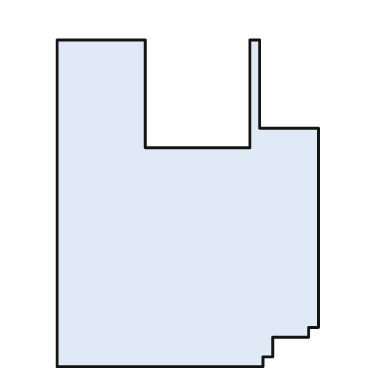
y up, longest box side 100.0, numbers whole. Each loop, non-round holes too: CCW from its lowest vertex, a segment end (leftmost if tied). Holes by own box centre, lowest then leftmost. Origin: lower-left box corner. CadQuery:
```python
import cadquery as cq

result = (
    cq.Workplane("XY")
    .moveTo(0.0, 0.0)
    .lineTo(63.0, 0.0)
    .lineTo(63.0, 3.0)
    .lineTo(66.0, 3.0)
    .lineTo(66.0, 9.0)
    .lineTo(77.0, 9.0)
    .lineTo(77.0, 12.0)
    .lineTo(80.0, 12.0)
    .lineTo(80.0, 73.0)
    .lineTo(62.0, 73.0)
    .lineTo(62.0, 100.0)
    .lineTo(59.0, 100.0)
    .lineTo(59.0, 67.0)
    .lineTo(27.0, 67.0)
    .lineTo(27.0, 100.0)
    .lineTo(0.0, 100.0)
    .close()
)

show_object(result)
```